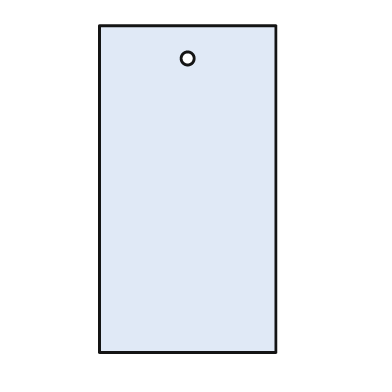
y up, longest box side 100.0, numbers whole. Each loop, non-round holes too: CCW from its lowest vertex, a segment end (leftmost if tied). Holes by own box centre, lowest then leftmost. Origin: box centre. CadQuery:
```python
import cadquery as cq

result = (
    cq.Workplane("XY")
    .moveTo(-27.0, -50.0)
    .lineTo(27.0, -50.0)
    .lineTo(27.0, 50.0)
    .lineTo(-27.0, 50.0)
    .close()
    .moveTo(0.0, 40.0)
    .circle(2.0)
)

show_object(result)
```